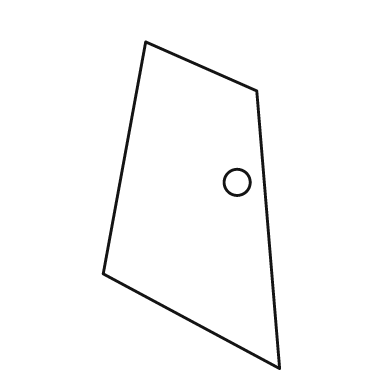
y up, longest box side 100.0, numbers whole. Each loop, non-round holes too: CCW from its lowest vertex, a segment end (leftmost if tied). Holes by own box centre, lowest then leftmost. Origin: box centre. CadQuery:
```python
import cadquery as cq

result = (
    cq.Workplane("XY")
    .moveTo(27.0, -50.0)
    .lineTo(20.0, 35.0)
    .lineTo(-14.0, 50.0)
    .lineTo(-27.0, -21.0)
    .close()
    .moveTo(14.0, 7.0)
    .circle(4.0)
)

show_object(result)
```